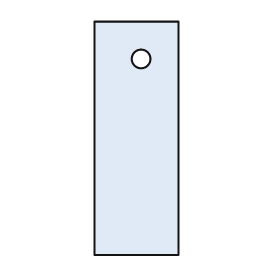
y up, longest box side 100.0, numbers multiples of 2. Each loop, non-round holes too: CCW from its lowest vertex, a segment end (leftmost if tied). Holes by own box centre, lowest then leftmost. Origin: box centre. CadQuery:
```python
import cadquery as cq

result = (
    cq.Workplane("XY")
    .moveTo(-18.0, -50.0)
    .lineTo(18.0, -50.0)
    .lineTo(18.0, 50.0)
    .lineTo(-18.0, 50.0)
    .close()
    .moveTo(2.0, 34.0)
    .circle(4.0)
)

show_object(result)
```